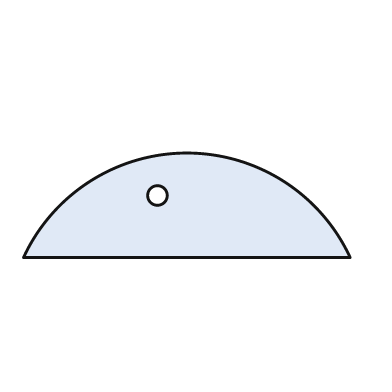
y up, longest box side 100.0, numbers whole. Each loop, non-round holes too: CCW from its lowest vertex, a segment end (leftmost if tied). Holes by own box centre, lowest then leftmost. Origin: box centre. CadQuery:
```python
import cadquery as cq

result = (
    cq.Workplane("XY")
    .moveTo(-50.0, -16.0)
    .lineTo(50.0, -16.0)
    .threePointArc((0.0, 16.0), (-50.0, -16.0))
    .close()
    .moveTo(-9.0, 3.0)
    .circle(3.0)
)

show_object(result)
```